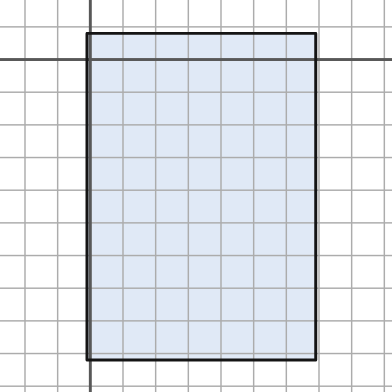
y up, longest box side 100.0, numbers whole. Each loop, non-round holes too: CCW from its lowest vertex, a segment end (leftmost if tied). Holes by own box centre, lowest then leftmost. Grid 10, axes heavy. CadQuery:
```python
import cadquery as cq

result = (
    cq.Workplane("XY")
    .moveTo(-1.0, -92.0)
    .lineTo(69.0, -92.0)
    .lineTo(69.0, 8.0)
    .lineTo(-1.0, 8.0)
    .close()
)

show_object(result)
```